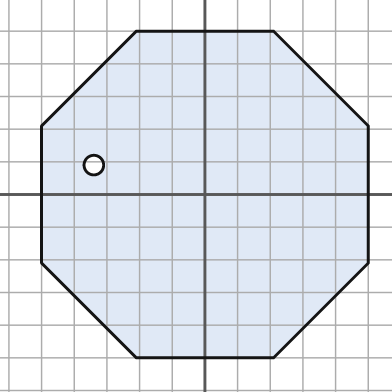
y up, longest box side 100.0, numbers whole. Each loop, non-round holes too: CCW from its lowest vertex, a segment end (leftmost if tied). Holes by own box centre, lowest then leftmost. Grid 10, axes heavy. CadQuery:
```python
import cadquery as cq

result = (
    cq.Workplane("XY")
    .moveTo(-21.0, -50.0)
    .lineTo(21.0, -50.0)
    .lineTo(50.0, -21.0)
    .lineTo(50.0, 21.0)
    .lineTo(21.0, 50.0)
    .lineTo(-21.0, 50.0)
    .lineTo(-50.0, 21.0)
    .lineTo(-50.0, -21.0)
    .close()
    .moveTo(-34.0, 9.0)
    .circle(3.0)
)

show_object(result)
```